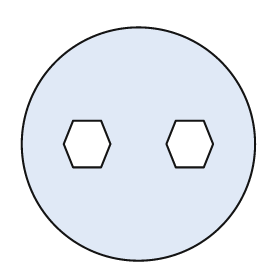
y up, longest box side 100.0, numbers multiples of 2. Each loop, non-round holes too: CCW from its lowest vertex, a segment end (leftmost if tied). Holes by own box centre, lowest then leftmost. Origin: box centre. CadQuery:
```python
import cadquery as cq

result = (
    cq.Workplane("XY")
    .moveTo(0.0, 0.0)
    .circle(50.0)
    .moveTo(-28.0, -10.0)
    .lineTo(-16.0, -10.0)
    .lineTo(-12.0, 0.0)
    .lineTo(-16.0, 10.0)
    .lineTo(-28.0, 10.0)
    .lineTo(-32.0, 0.0)
    .close()
    .moveTo(16.0, -10.0)
    .lineTo(28.0, -10.0)
    .lineTo(32.0, 0.0)
    .lineTo(28.0, 10.0)
    .lineTo(16.0, 10.0)
    .lineTo(12.0, 0.0)
    .close()
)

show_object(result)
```